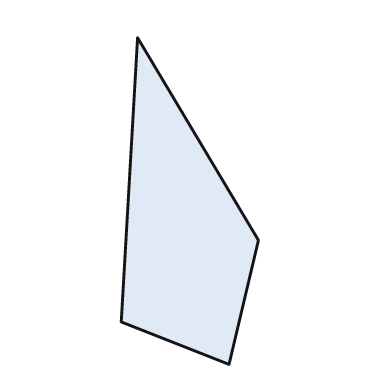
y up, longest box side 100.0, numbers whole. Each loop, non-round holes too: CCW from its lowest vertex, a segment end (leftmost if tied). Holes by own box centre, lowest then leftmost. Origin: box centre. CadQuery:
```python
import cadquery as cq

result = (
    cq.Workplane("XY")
    .moveTo(12.0, -50.0)
    .lineTo(21.0, -12.0)
    .lineTo(-16.0, 50.0)
    .lineTo(-21.0, -37.0)
    .close()
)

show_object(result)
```